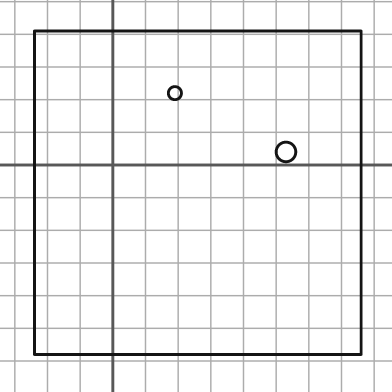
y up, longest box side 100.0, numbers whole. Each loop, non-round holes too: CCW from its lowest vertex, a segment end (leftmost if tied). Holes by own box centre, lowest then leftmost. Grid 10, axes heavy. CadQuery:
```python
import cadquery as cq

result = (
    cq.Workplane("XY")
    .moveTo(-24.0, -58.0)
    .lineTo(76.0, -58.0)
    .lineTo(76.0, 41.0)
    .lineTo(-24.0, 41.0)
    .close()
    .moveTo(53.0, 4.0)
    .circle(3.0)
    .moveTo(19.0, 22.0)
    .circle(2.0)
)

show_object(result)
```